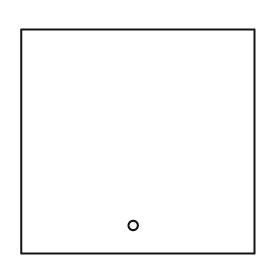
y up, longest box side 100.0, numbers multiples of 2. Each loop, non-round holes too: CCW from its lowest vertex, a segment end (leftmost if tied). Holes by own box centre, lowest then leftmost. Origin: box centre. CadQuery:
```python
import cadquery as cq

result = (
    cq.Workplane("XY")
    .moveTo(-50.0, -48.0)
    .lineTo(50.0, -48.0)
    .lineTo(50.0, 48.0)
    .lineTo(-50.0, 48.0)
    .close()
    .moveTo(-2.0, -36.0)
    .circle(2.0)
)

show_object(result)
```